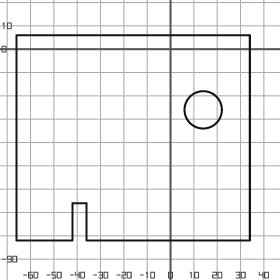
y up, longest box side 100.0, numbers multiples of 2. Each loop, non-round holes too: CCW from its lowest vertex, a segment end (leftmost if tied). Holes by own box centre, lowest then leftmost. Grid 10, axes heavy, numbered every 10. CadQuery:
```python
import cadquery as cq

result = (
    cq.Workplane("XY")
    .moveTo(-66.0, -82.0)
    .lineTo(-42.0, -82.0)
    .lineTo(-42.0, -66.0)
    .lineTo(-36.0, -66.0)
    .lineTo(-36.0, -82.0)
    .lineTo(34.0, -82.0)
    .lineTo(34.0, 6.0)
    .lineTo(-66.0, 6.0)
    .close()
    .moveTo(14.0, -26.0)
    .circle(8.0)
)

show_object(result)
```